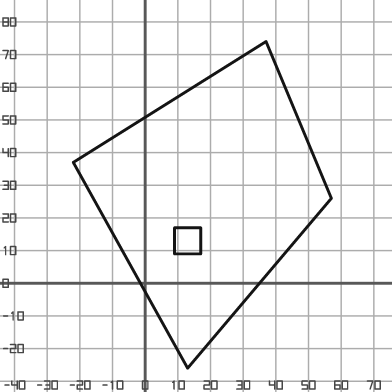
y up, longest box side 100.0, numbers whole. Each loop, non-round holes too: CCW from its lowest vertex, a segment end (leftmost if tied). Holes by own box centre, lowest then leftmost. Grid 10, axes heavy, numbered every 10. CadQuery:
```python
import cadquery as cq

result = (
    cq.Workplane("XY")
    .moveTo(13.0, -26.0)
    .lineTo(57.0, 26.0)
    .lineTo(37.0, 74.0)
    .lineTo(-22.0, 37.0)
    .close()
    .moveTo(9.0, 9.0)
    .lineTo(17.0, 9.0)
    .lineTo(17.0, 17.0)
    .lineTo(9.0, 17.0)
    .close()
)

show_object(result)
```